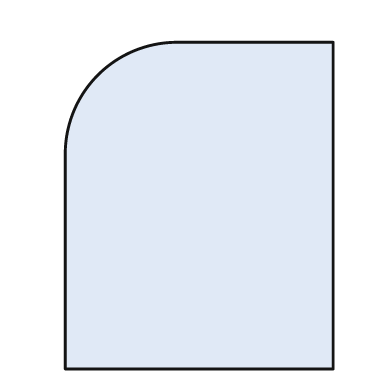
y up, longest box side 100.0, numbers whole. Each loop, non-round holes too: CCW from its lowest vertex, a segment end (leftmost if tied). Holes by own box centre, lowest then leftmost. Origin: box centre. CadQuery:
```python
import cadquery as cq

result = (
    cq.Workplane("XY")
    .moveTo(-41.0, -50.0)
    .lineTo(41.0, -50.0)
    .lineTo(41.0, 50.0)
    .lineTo(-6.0, 50.0)
    .threePointArc((-31.0, 40.0), (-41.0, 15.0))
    .close()
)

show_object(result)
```